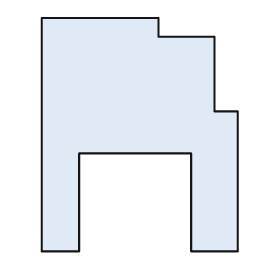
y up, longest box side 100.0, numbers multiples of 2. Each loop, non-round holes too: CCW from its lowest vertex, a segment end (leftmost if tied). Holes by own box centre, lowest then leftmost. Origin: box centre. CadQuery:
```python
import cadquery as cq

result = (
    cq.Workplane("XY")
    .moveTo(-42.0, -50.0)
    .lineTo(-26.0, -50.0)
    .lineTo(-26.0, -8.0)
    .lineTo(22.0, -8.0)
    .lineTo(22.0, -50.0)
    .lineTo(42.0, -50.0)
    .lineTo(42.0, 10.0)
    .lineTo(32.0, 10.0)
    .lineTo(32.0, 42.0)
    .lineTo(8.0, 42.0)
    .lineTo(8.0, 50.0)
    .lineTo(-42.0, 50.0)
    .close()
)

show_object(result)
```